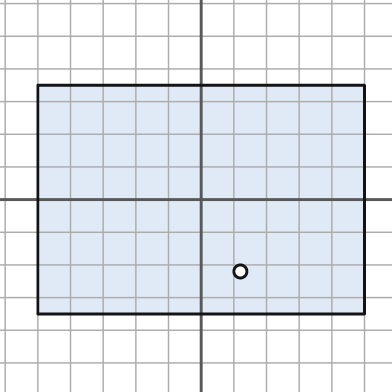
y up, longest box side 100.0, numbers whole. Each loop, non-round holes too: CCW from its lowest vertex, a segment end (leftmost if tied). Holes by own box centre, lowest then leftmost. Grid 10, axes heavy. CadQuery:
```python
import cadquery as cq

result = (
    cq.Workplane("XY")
    .moveTo(-50.0, -35.0)
    .lineTo(50.0, -35.0)
    .lineTo(50.0, 35.0)
    .lineTo(-50.0, 35.0)
    .close()
    .moveTo(12.0, -22.0)
    .circle(2.0)
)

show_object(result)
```